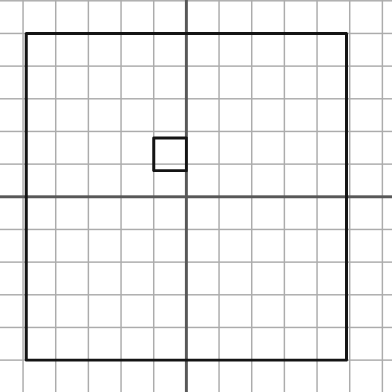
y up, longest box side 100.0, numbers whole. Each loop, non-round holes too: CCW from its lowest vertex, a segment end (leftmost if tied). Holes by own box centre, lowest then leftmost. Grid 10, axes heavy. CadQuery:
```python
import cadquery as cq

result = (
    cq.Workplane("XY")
    .moveTo(-49.0, -50.0)
    .lineTo(49.0, -50.0)
    .lineTo(49.0, 50.0)
    .lineTo(-49.0, 50.0)
    .close()
    .moveTo(-10.0, 8.0)
    .lineTo(0.0, 8.0)
    .lineTo(0.0, 18.0)
    .lineTo(-10.0, 18.0)
    .close()
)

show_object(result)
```